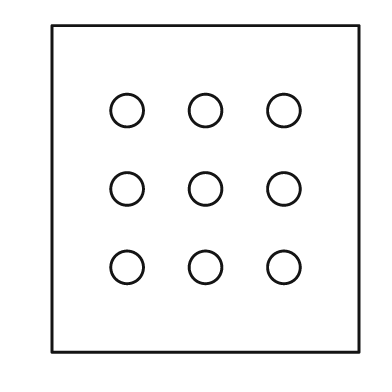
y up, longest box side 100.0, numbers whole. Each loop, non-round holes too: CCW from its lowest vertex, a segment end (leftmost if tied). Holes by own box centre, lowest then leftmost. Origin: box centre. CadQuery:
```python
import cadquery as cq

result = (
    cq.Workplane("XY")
    .moveTo(-47.0, -50.0)
    .lineTo(47.0, -50.0)
    .lineTo(47.0, 50.0)
    .lineTo(-47.0, 50.0)
    .close()
    .moveTo(-24.0, -24.0)
    .circle(5.0)
    .moveTo(0.0, -24.0)
    .circle(5.0)
    .moveTo(24.0, -24.0)
    .circle(5.0)
    .moveTo(-24.0, 0.0)
    .circle(5.0)
    .moveTo(0.0, 0.0)
    .circle(5.0)
    .moveTo(24.0, 0.0)
    .circle(5.0)
    .moveTo(-24.0, 24.0)
    .circle(5.0)
    .moveTo(0.0, 24.0)
    .circle(5.0)
    .moveTo(24.0, 24.0)
    .circle(5.0)
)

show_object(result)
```